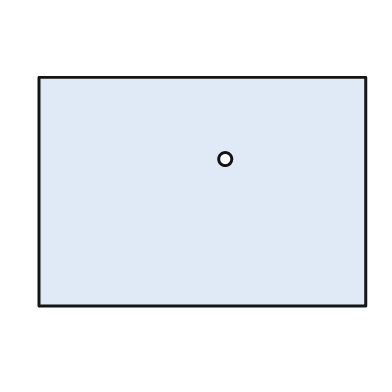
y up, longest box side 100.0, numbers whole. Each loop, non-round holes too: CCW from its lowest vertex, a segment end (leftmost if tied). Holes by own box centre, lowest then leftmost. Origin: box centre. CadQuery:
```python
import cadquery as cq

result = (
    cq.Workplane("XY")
    .moveTo(-50.0, -35.0)
    .lineTo(50.0, -35.0)
    .lineTo(50.0, 35.0)
    .lineTo(-50.0, 35.0)
    .close()
    .moveTo(7.0, 10.0)
    .circle(2.0)
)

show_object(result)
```